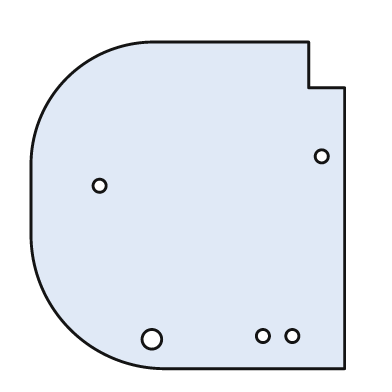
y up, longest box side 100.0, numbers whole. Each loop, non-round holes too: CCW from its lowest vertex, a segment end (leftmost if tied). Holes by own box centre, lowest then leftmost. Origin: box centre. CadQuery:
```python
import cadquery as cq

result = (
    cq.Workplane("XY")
    .moveTo(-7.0, -50.0)
    .lineTo(48.0, -50.0)
    .lineTo(48.0, 36.0)
    .lineTo(37.0, 36.0)
    .lineTo(37.0, 50.0)
    .lineTo(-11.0, 50.0)
    .threePointArc((-37.0, 39.0), (-48.0, 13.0))
    .lineTo(-48.0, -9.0)
    .threePointArc((-36.0, -38.0), (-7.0, -50.0))
    .close()
    .moveTo(-11.0, -41.0)
    .circle(3.0)
    .moveTo(23.0, -40.0)
    .circle(2.0)
    .moveTo(32.0, -40.0)
    .circle(2.0)
    .moveTo(-27.0, 6.0)
    .circle(2.0)
    .moveTo(41.0, 15.0)
    .circle(2.0)
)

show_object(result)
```